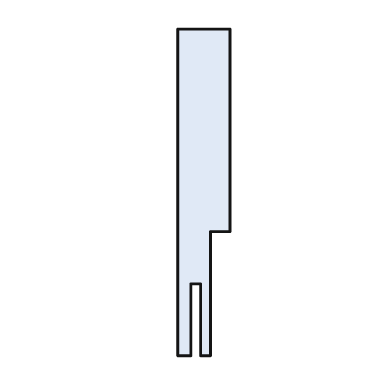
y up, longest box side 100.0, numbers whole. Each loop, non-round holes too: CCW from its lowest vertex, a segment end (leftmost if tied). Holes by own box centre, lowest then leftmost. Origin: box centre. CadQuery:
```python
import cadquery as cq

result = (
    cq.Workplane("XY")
    .moveTo(-8.0, -50.0)
    .lineTo(-4.0, -50.0)
    .lineTo(-4.0, -28.0)
    .lineTo(-1.0, -28.0)
    .lineTo(-1.0, -50.0)
    .lineTo(2.0, -50.0)
    .lineTo(2.0, -12.0)
    .lineTo(8.0, -12.0)
    .lineTo(8.0, 50.0)
    .lineTo(-8.0, 50.0)
    .close()
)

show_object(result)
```